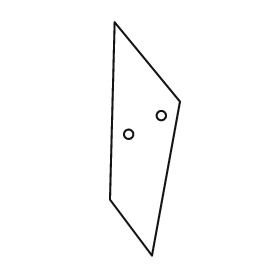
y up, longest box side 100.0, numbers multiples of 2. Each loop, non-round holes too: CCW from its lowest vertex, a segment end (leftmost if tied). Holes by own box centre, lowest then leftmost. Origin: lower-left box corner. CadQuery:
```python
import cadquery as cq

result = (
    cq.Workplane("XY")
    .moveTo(18.0, 0.0)
    .lineTo(30.0, 66.0)
    .lineTo(2.0, 100.0)
    .lineTo(0.0, 24.0)
    .close()
    .moveTo(8.0, 52.0)
    .circle(2.0)
    .moveTo(22.0, 60.0)
    .circle(2.0)
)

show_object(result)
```